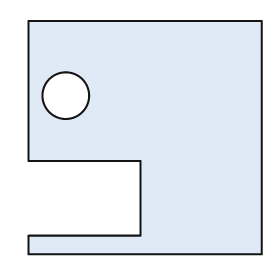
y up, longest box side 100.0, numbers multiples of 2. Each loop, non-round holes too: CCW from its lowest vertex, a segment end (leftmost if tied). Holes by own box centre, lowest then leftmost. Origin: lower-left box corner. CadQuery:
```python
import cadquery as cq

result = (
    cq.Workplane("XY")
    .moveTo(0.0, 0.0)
    .lineTo(100.0, 0.0)
    .lineTo(100.0, 100.0)
    .lineTo(0.0, 100.0)
    .lineTo(0.0, 40.0)
    .lineTo(48.0, 40.0)
    .lineTo(48.0, 8.0)
    .lineTo(0.0, 8.0)
    .close()
    .moveTo(16.0, 68.0)
    .circle(10.0)
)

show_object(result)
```